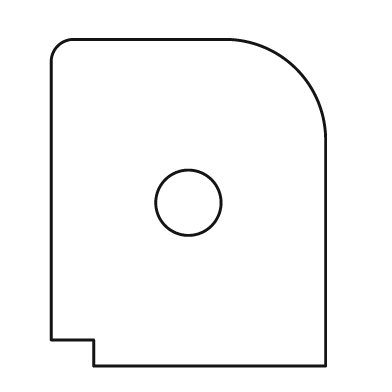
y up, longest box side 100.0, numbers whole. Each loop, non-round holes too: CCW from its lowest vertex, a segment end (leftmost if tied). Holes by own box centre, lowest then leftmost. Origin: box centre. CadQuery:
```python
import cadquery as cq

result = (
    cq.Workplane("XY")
    .moveTo(-29.0, -50.0)
    .lineTo(42.0, -50.0)
    .lineTo(42.0, 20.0)
    .threePointArc((33.0, 41.0), (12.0, 50.0))
    .lineTo(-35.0, 50.0)
    .threePointArc((-40.0, 48.0), (-42.0, 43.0))
    .lineTo(-42.0, -42.0)
    .lineTo(-29.0, -42.0)
    .close()
    .moveTo(0.0, 0.0)
    .circle(10.0)
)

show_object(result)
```